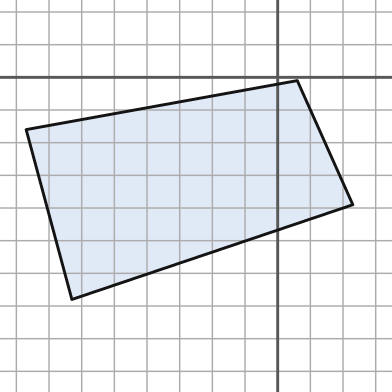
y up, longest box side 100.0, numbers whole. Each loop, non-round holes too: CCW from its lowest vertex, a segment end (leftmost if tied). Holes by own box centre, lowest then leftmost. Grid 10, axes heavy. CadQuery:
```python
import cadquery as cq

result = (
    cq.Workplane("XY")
    .moveTo(-63.0, -68.0)
    .lineTo(23.0, -39.0)
    .lineTo(6.0, -1.0)
    .lineTo(-77.0, -16.0)
    .close()
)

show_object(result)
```